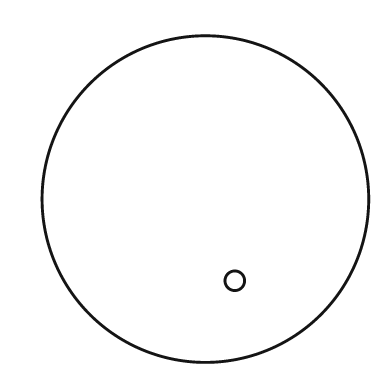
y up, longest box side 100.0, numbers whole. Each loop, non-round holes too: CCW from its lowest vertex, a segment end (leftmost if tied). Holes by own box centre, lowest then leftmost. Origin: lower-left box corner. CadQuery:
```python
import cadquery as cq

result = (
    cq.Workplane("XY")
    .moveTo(50.0, 50.0)
    .circle(50.0)
    .moveTo(59.0, 25.0)
    .circle(3.0)
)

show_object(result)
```